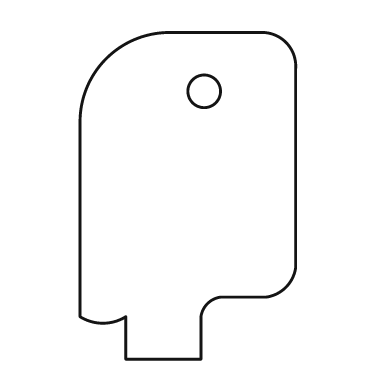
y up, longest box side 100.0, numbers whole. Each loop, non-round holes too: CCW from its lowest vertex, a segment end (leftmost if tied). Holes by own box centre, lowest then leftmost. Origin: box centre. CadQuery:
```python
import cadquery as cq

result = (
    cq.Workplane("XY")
    .moveTo(-19.0, -50.0)
    .lineTo(4.0, -50.0)
    .lineTo(4.0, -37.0)
    .threePointArc((6.0, -33.0), (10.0, -31.0))
    .lineTo(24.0, -31.0)
    .threePointArc((30.0, -28.0), (33.0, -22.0))
    .lineTo(33.0, 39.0)
    .threePointArc((30.0, 47.0), (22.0, 50.0))
    .lineTo(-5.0, 50.0)
    .threePointArc((-25.0, 42.0), (-33.0, 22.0))
    .lineTo(-33.0, -37.0)
    .threePointArc((-26.0, -39.0), (-19.0, -37.0))
    .close()
    .moveTo(5.0, 32.0)
    .circle(5.0)
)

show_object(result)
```